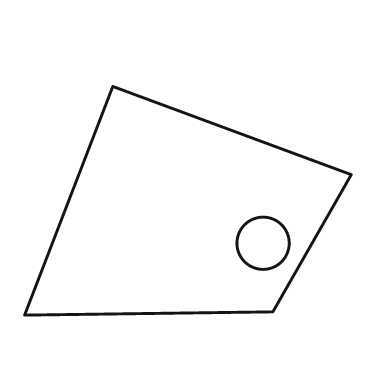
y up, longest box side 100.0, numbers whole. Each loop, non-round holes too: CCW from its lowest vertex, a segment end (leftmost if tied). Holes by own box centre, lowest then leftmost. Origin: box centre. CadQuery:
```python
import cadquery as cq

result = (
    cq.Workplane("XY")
    .moveTo(-50.0, -35.0)
    .lineTo(26.0, -34.0)
    .lineTo(50.0, 8.0)
    .lineTo(-23.0, 35.0)
    .close()
    .moveTo(23.0, -13.0)
    .circle(8.0)
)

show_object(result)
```